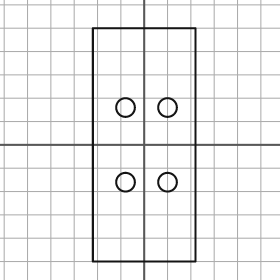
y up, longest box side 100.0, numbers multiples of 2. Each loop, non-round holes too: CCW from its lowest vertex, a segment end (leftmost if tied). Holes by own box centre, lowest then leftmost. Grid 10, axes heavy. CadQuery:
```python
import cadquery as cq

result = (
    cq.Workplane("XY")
    .moveTo(-22.0, -50.0)
    .lineTo(22.0, -50.0)
    .lineTo(22.0, 50.0)
    .lineTo(-22.0, 50.0)
    .close()
    .moveTo(-8.0, -16.0)
    .circle(4.0)
    .moveTo(10.0, -16.0)
    .circle(4.0)
    .moveTo(-8.0, 16.0)
    .circle(4.0)
    .moveTo(10.0, 16.0)
    .circle(4.0)
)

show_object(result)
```